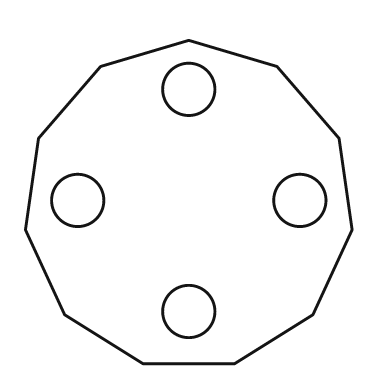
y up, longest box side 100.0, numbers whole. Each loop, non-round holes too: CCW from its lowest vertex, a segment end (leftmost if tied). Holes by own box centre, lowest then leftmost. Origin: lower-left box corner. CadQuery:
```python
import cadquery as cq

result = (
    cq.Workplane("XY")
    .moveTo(36.0, 0.0)
    .lineTo(64.0, 0.0)
    .lineTo(88.0, 15.0)
    .lineTo(100.0, 41.0)
    .lineTo(96.0, 69.0)
    .lineTo(77.0, 91.0)
    .lineTo(50.0, 99.0)
    .lineTo(23.0, 91.0)
    .lineTo(4.0, 69.0)
    .lineTo(0.0, 41.0)
    .lineTo(12.0, 15.0)
    .close()
    .moveTo(50.0, 16.0)
    .circle(8.0)
    .moveTo(16.0, 50.0)
    .circle(8.0)
    .moveTo(84.0, 50.0)
    .circle(8.0)
    .moveTo(50.0, 84.0)
    .circle(8.0)
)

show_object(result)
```